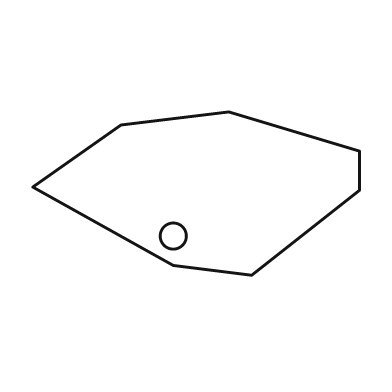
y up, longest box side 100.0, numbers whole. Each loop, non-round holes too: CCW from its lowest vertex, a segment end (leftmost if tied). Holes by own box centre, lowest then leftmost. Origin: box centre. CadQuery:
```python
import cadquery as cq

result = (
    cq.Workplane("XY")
    .moveTo(17.0, -25.0)
    .lineTo(50.0, 1.0)
    .lineTo(50.0, 13.0)
    .lineTo(10.0, 25.0)
    .lineTo(-23.0, 21.0)
    .lineTo(-50.0, 2.0)
    .lineTo(-7.0, -22.0)
    .close()
    .moveTo(-7.0, -13.0)
    .circle(4.0)
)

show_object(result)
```